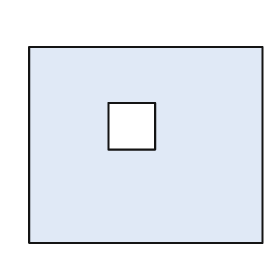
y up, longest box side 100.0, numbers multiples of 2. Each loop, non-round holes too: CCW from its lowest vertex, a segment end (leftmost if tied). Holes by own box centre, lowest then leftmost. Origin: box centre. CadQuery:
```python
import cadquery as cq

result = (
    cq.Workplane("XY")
    .moveTo(-50.0, -42.0)
    .lineTo(50.0, -42.0)
    .lineTo(50.0, 42.0)
    .lineTo(-50.0, 42.0)
    .close()
    .moveTo(-16.0, -2.0)
    .lineTo(4.0, -2.0)
    .lineTo(4.0, 18.0)
    .lineTo(-16.0, 18.0)
    .close()
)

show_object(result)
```